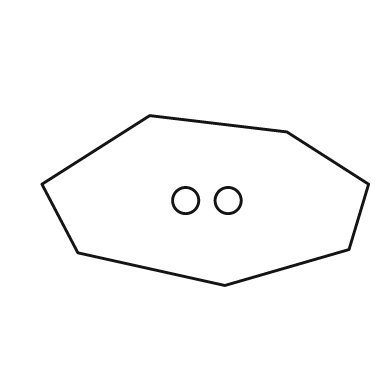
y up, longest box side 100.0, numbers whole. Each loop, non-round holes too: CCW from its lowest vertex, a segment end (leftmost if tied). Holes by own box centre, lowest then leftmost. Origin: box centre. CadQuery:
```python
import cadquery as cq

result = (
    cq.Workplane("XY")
    .moveTo(6.0, -26.0)
    .lineTo(44.0, -15.0)
    .lineTo(50.0, 5.0)
    .lineTo(25.0, 21.0)
    .lineTo(-17.0, 26.0)
    .lineTo(-50.0, 5.0)
    .lineTo(-39.0, -16.0)
    .close()
    .moveTo(-6.0, 0.0)
    .circle(4.0)
    .moveTo(7.0, 0.0)
    .circle(4.0)
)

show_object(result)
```